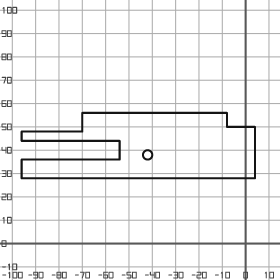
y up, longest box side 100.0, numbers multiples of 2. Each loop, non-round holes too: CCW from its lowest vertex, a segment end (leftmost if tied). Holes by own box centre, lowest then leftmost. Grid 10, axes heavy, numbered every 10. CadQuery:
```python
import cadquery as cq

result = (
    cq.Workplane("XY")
    .moveTo(-96.0, 28.0)
    .lineTo(4.0, 28.0)
    .lineTo(4.0, 50.0)
    .lineTo(-8.0, 50.0)
    .lineTo(-8.0, 56.0)
    .lineTo(-70.0, 56.0)
    .lineTo(-70.0, 48.0)
    .lineTo(-96.0, 48.0)
    .lineTo(-96.0, 44.0)
    .lineTo(-54.0, 44.0)
    .lineTo(-54.0, 36.0)
    .lineTo(-96.0, 36.0)
    .close()
    .moveTo(-42.0, 38.0)
    .circle(2.0)
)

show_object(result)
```